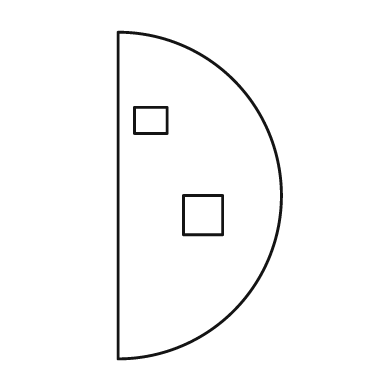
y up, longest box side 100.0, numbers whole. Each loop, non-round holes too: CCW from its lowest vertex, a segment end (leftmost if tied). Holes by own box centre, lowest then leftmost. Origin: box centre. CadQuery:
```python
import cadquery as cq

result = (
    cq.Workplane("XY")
    .moveTo(-25.0, -50.0)
    .threePointArc((25.0, 0.0), (-25.0, 50.0))
    .close()
    .moveTo(-5.0, -12.0)
    .lineTo(7.0, -12.0)
    .lineTo(7.0, 0.0)
    .lineTo(-5.0, 0.0)
    .close()
    .moveTo(-20.0, 19.0)
    .lineTo(-10.0, 19.0)
    .lineTo(-10.0, 27.0)
    .lineTo(-20.0, 27.0)
    .close()
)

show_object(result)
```